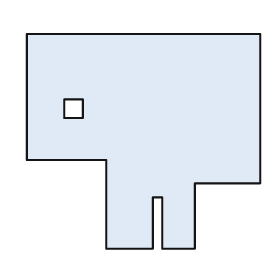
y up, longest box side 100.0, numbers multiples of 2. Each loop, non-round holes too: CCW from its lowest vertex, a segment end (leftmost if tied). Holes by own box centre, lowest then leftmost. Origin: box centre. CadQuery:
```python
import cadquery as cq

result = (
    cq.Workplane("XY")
    .moveTo(-16.0, -46.0)
    .lineTo(4.0, -46.0)
    .lineTo(4.0, -24.0)
    .lineTo(8.0, -24.0)
    .lineTo(8.0, -46.0)
    .lineTo(22.0, -46.0)
    .lineTo(22.0, -18.0)
    .lineTo(50.0, -18.0)
    .lineTo(50.0, 46.0)
    .lineTo(-50.0, 46.0)
    .lineTo(-50.0, -8.0)
    .lineTo(-16.0, -8.0)
    .close()
    .moveTo(-34.0, 10.0)
    .lineTo(-26.0, 10.0)
    .lineTo(-26.0, 18.0)
    .lineTo(-34.0, 18.0)
    .close()
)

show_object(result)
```